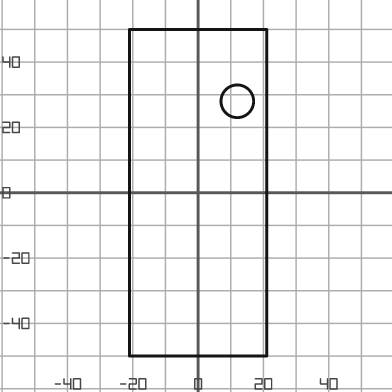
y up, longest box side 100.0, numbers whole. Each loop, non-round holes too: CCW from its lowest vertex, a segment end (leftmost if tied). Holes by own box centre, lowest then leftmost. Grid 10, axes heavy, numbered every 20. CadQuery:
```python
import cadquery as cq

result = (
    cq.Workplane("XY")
    .moveTo(-21.0, -50.0)
    .lineTo(21.0, -50.0)
    .lineTo(21.0, 50.0)
    .lineTo(-21.0, 50.0)
    .close()
    .moveTo(12.0, 28.0)
    .circle(5.0)
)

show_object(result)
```